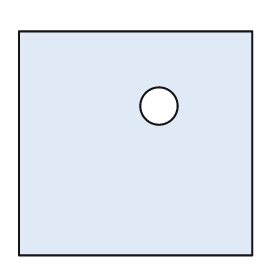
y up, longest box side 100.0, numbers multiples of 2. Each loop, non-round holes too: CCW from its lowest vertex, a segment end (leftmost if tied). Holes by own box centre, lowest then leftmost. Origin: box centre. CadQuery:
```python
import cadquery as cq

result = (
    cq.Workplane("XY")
    .moveTo(-50.0, -48.0)
    .lineTo(50.0, -48.0)
    .lineTo(50.0, 48.0)
    .lineTo(-50.0, 48.0)
    .close()
    .moveTo(10.0, 16.0)
    .circle(8.0)
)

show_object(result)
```